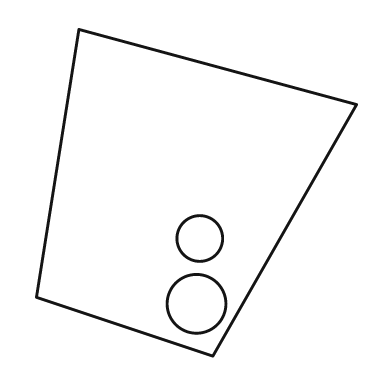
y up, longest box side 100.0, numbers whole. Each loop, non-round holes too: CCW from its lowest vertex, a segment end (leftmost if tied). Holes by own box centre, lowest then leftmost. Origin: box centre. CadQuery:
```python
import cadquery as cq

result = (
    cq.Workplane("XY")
    .moveTo(5.0, -50.0)
    .lineTo(49.0, 27.0)
    .lineTo(-36.0, 50.0)
    .lineTo(-49.0, -32.0)
    .close()
    .moveTo(0.0, -34.0)
    .circle(9.0)
    .moveTo(1.0, -14.0)
    .circle(7.0)
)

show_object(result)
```